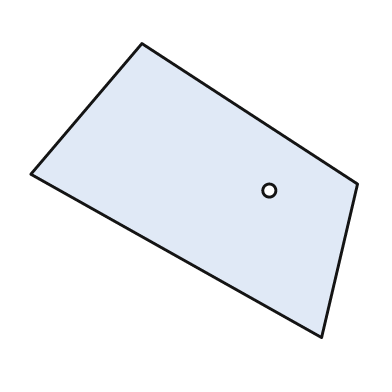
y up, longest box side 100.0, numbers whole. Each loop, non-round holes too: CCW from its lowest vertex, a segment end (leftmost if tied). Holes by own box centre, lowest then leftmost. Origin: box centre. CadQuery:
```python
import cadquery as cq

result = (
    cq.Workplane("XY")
    .moveTo(39.0, -45.0)
    .lineTo(50.0, 2.0)
    .lineTo(-16.0, 45.0)
    .lineTo(-50.0, 5.0)
    .close()
    .moveTo(23.0, 0.0)
    .circle(2.0)
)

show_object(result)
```